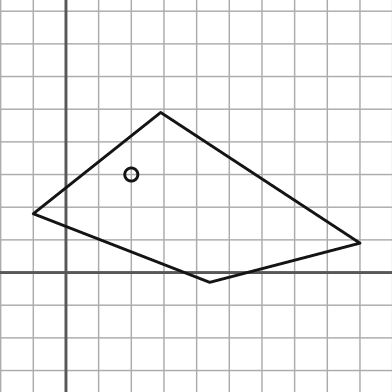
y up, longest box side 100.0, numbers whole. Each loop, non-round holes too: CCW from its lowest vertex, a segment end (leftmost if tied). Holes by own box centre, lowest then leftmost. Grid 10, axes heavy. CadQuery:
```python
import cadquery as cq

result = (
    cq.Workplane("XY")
    .moveTo(44.0, -3.0)
    .lineTo(90.0, 9.0)
    .lineTo(29.0, 49.0)
    .lineTo(-10.0, 18.0)
    .close()
    .moveTo(20.0, 30.0)
    .circle(2.0)
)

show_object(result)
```